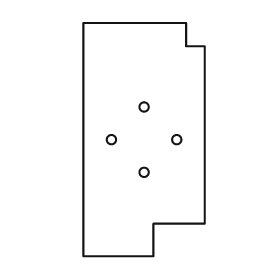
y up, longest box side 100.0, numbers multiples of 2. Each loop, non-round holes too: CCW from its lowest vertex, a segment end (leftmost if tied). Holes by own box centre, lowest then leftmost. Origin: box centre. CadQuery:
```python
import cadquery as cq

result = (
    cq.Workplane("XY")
    .moveTo(-26.0, -50.0)
    .lineTo(4.0, -50.0)
    .lineTo(4.0, -36.0)
    .lineTo(26.0, -36.0)
    .lineTo(26.0, 40.0)
    .lineTo(18.0, 40.0)
    .lineTo(18.0, 50.0)
    .lineTo(-26.0, 50.0)
    .close()
    .moveTo(0.0, -14.0)
    .circle(2.0)
    .moveTo(-14.0, 0.0)
    .circle(2.0)
    .moveTo(14.0, 0.0)
    .circle(2.0)
    .moveTo(0.0, 14.0)
    .circle(2.0)
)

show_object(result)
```